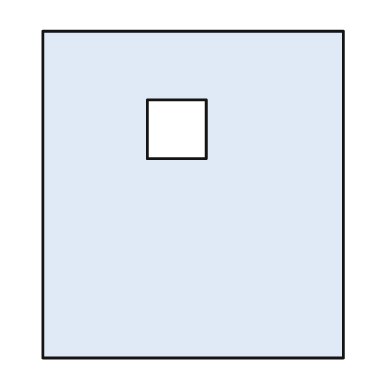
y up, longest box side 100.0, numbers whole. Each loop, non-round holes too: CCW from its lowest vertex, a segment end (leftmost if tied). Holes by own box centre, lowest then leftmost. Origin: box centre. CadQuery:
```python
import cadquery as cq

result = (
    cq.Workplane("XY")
    .moveTo(-46.0, -50.0)
    .lineTo(46.0, -50.0)
    .lineTo(46.0, 50.0)
    .lineTo(-46.0, 50.0)
    .close()
    .moveTo(-14.0, 11.0)
    .lineTo(4.0, 11.0)
    .lineTo(4.0, 29.0)
    .lineTo(-14.0, 29.0)
    .close()
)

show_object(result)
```